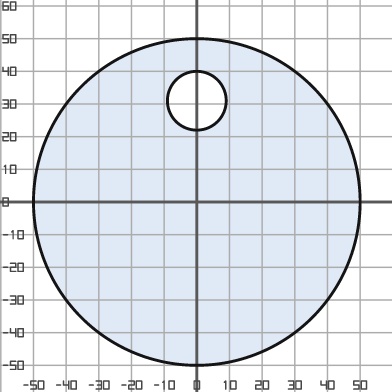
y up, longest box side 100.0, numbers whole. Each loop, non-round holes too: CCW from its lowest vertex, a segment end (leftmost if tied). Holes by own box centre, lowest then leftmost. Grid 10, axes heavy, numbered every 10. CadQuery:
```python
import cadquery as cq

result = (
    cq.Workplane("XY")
    .moveTo(0.0, 0.0)
    .circle(50.0)
    .moveTo(0.0, 31.0)
    .circle(9.0)
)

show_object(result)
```